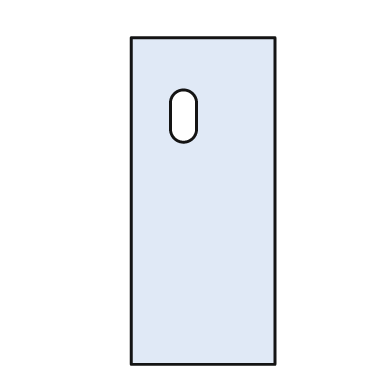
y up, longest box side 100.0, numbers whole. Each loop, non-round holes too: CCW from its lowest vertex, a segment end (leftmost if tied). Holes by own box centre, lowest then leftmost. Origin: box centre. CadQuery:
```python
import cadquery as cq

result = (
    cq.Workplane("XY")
    .moveTo(-22.0, -50.0)
    .lineTo(22.0, -50.0)
    .lineTo(22.0, 50.0)
    .lineTo(-22.0, 50.0)
    .close()
    .moveTo(-10.0, 22.0)
    .threePointArc((-6.0, 18.0), (-2.0, 22.0))
    .lineTo(-2.0, 30.0)
    .threePointArc((-6.0, 34.0), (-10.0, 30.0))
    .close()
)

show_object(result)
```